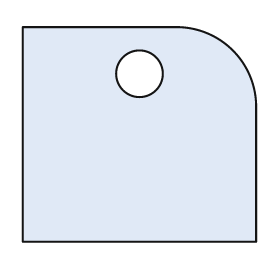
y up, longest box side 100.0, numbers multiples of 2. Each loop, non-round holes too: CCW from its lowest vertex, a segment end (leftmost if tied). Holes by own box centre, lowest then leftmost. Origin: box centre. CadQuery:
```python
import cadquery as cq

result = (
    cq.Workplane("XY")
    .moveTo(-50.0, -46.0)
    .lineTo(50.0, -46.0)
    .lineTo(50.0, 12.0)
    .threePointArc((40.0, 36.0), (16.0, 46.0))
    .lineTo(-50.0, 46.0)
    .close()
    .moveTo(0.0, 26.0)
    .circle(10.0)
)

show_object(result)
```